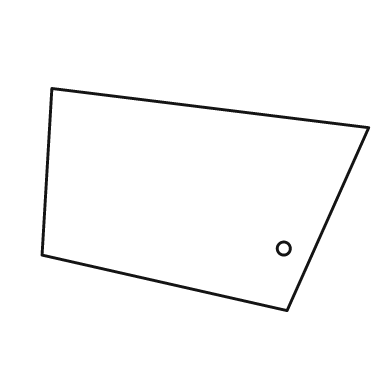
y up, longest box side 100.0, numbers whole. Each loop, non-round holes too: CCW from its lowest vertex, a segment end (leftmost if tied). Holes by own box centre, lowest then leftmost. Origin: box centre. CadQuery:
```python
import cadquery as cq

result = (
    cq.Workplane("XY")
    .moveTo(25.0, -34.0)
    .lineTo(50.0, 22.0)
    .lineTo(-47.0, 34.0)
    .lineTo(-50.0, -17.0)
    .close()
    .moveTo(24.0, -15.0)
    .circle(2.0)
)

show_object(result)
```